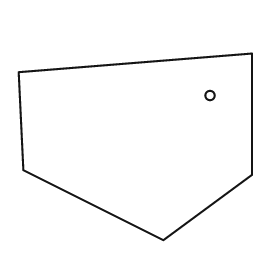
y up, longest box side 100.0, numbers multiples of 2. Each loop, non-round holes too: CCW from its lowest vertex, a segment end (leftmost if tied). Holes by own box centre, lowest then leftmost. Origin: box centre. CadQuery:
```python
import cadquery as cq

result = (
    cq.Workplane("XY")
    .moveTo(12.0, -40.0)
    .lineTo(50.0, -12.0)
    .lineTo(50.0, 40.0)
    .lineTo(-50.0, 32.0)
    .lineTo(-48.0, -10.0)
    .close()
    .moveTo(32.0, 22.0)
    .circle(2.0)
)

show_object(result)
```